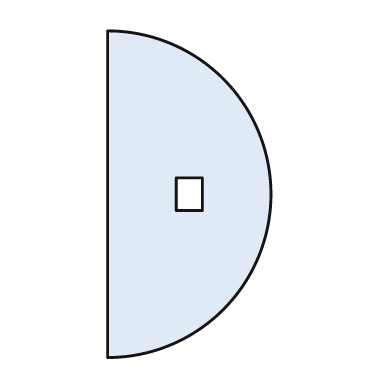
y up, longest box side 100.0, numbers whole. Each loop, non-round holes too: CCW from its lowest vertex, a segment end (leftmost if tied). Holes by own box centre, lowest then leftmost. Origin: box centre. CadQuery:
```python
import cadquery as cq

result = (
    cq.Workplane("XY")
    .moveTo(-25.0, -50.0)
    .threePointArc((25.0, 0.0), (-25.0, 50.0))
    .close()
    .moveTo(-4.0, -5.0)
    .lineTo(4.0, -5.0)
    .lineTo(4.0, 5.0)
    .lineTo(-4.0, 5.0)
    .close()
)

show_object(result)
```